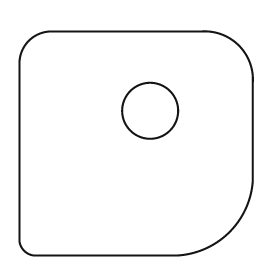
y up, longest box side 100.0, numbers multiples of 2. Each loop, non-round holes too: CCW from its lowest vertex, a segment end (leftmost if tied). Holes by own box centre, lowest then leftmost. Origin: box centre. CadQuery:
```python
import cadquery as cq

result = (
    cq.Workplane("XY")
    .moveTo(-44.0, -48.0)
    .lineTo(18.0, -48.0)
    .threePointArc((40.0, -38.0), (50.0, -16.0))
    .lineTo(50.0, 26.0)
    .threePointArc((44.0, 42.0), (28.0, 48.0))
    .lineTo(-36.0, 48.0)
    .threePointArc((-46.0, 44.0), (-50.0, 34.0))
    .lineTo(-50.0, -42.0)
    .threePointArc((-48.0, -46.0), (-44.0, -48.0))
    .close()
    .moveTo(6.0, 14.0)
    .circle(12.0)
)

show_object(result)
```